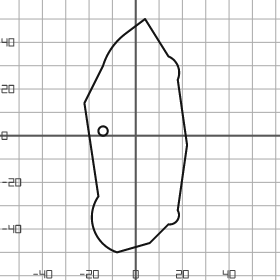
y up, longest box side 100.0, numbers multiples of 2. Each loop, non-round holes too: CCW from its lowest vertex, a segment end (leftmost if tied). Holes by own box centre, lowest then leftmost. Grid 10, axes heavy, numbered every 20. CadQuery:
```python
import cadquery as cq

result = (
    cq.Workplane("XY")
    .moveTo(-8.0, -50.0)
    .lineTo(6.0, -46.0)
    .lineTo(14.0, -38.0)
    .threePointArc((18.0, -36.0), (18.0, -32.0))
    .lineTo(22.0, -4.0)
    .lineTo(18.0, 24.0)
    .threePointArc((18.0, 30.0), (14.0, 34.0))
    .lineTo(4.0, 50.0)
    .lineTo(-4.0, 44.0)
    .threePointArc((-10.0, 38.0), (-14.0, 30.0))
    .lineTo(-22.0, 14.0)
    .lineTo(-16.0, -26.0)
    .threePointArc((-18.0, -40.0), (-8.0, -50.0))
    .close()
    .moveTo(-14.0, 2.0)
    .circle(2.0)
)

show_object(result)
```